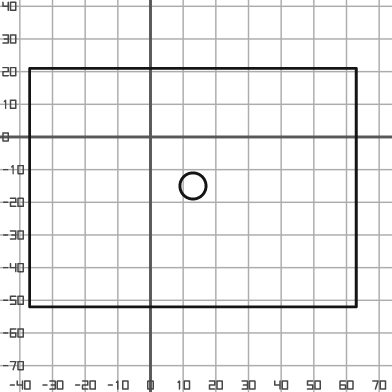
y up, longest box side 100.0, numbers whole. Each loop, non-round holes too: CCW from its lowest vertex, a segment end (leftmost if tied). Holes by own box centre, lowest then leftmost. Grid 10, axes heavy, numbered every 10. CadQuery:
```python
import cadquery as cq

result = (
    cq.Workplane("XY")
    .moveTo(-37.0, -52.0)
    .lineTo(63.0, -52.0)
    .lineTo(63.0, 21.0)
    .lineTo(-37.0, 21.0)
    .close()
    .moveTo(13.0, -15.0)
    .circle(4.0)
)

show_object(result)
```